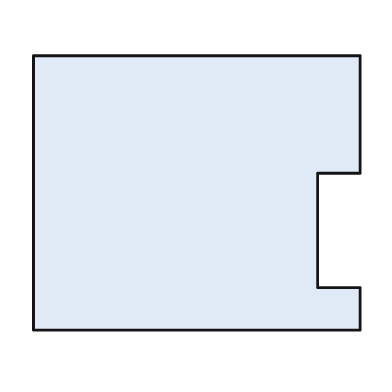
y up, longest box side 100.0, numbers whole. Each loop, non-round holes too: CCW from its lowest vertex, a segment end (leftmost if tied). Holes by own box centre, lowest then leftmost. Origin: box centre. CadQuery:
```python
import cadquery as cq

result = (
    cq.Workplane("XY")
    .moveTo(-50.0, -42.0)
    .lineTo(50.0, -42.0)
    .lineTo(50.0, -29.0)
    .lineTo(37.0, -29.0)
    .lineTo(37.0, 6.0)
    .lineTo(50.0, 6.0)
    .lineTo(50.0, 42.0)
    .lineTo(-50.0, 42.0)
    .close()
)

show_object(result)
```